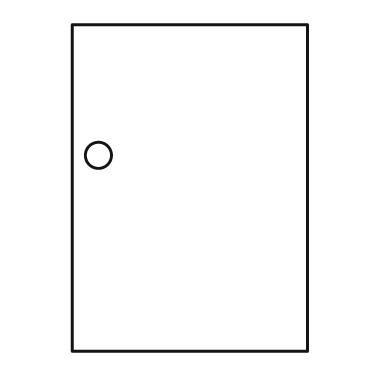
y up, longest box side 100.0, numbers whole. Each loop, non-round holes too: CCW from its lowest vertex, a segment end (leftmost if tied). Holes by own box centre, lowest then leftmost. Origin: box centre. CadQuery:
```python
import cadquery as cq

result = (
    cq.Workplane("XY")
    .moveTo(-36.0, -50.0)
    .lineTo(36.0, -50.0)
    .lineTo(36.0, 50.0)
    .lineTo(-36.0, 50.0)
    .close()
    .moveTo(-28.0, 10.0)
    .circle(4.0)
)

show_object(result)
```